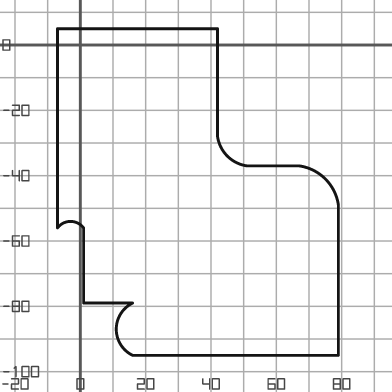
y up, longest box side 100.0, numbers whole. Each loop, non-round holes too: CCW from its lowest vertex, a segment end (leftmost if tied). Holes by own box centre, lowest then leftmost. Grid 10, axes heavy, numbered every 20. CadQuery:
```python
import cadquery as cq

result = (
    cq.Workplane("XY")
    .moveTo(16.0, -95.0)
    .lineTo(79.0, -95.0)
    .lineTo(79.0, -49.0)
    .threePointArc((75.0, -41.0), (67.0, -37.0))
    .lineTo(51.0, -37.0)
    .threePointArc((45.0, -34.0), (42.0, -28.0))
    .lineTo(42.0, 5.0)
    .lineTo(-7.0, 5.0)
    .lineTo(-7.0, -56.0)
    .threePointArc((-3.0, -54.0), (1.0, -56.0))
    .lineTo(1.0, -79.0)
    .lineTo(16.0, -79.0)
    .threePointArc((11.0, -87.0), (16.0, -95.0))
    .close()
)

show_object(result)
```